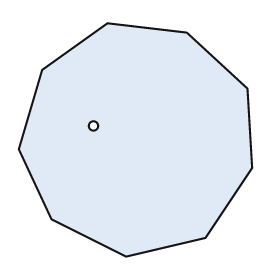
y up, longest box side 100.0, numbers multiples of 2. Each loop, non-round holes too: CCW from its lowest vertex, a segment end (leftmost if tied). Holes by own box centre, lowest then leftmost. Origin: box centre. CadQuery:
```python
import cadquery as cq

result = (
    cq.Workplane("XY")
    .moveTo(-4.0, -50.0)
    .lineTo(30.0, -42.0)
    .lineTo(50.0, -12.0)
    .lineTo(48.0, 22.0)
    .lineTo(22.0, 46.0)
    .lineTo(-12.0, 50.0)
    .lineTo(-40.0, 30.0)
    .lineTo(-50.0, -4.0)
    .lineTo(-36.0, -34.0)
    .close()
    .moveTo(-18.0, 6.0)
    .circle(2.0)
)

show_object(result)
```